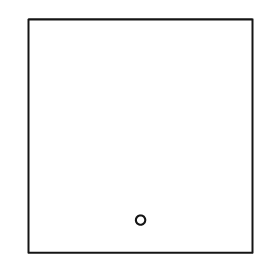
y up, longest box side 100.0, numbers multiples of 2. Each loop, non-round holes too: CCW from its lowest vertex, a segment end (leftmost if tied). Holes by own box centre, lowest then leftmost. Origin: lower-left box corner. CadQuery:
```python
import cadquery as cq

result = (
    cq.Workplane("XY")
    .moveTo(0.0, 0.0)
    .lineTo(96.0, 0.0)
    .lineTo(96.0, 100.0)
    .lineTo(0.0, 100.0)
    .close()
    .moveTo(48.0, 14.0)
    .circle(2.0)
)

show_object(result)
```